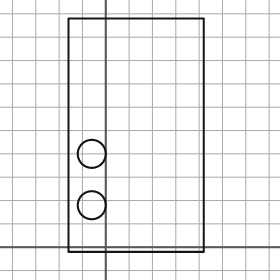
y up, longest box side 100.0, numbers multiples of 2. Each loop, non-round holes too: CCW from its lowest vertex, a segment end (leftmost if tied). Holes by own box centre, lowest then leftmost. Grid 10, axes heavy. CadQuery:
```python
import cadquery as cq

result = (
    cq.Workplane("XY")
    .moveTo(-16.0, -2.0)
    .lineTo(42.0, -2.0)
    .lineTo(42.0, 98.0)
    .lineTo(-16.0, 98.0)
    .close()
    .moveTo(-6.0, 18.0)
    .circle(6.0)
    .moveTo(-6.0, 40.0)
    .circle(6.0)
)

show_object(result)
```